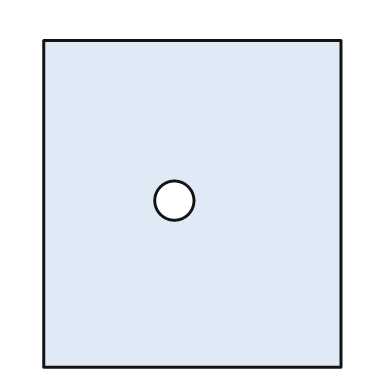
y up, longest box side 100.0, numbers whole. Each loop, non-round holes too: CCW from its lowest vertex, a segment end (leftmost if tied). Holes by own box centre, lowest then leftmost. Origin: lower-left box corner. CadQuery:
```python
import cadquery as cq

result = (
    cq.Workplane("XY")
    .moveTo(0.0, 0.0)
    .lineTo(91.0, 0.0)
    .lineTo(91.0, 100.0)
    .lineTo(0.0, 100.0)
    .close()
    .moveTo(40.0, 51.0)
    .circle(6.0)
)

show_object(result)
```